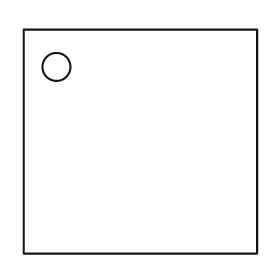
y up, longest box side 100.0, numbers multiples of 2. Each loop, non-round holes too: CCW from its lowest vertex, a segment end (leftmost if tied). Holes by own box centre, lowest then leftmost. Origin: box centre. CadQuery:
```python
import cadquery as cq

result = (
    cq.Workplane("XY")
    .moveTo(-50.0, -48.0)
    .lineTo(50.0, -48.0)
    .lineTo(50.0, 48.0)
    .lineTo(-50.0, 48.0)
    .close()
    .moveTo(-36.0, 32.0)
    .circle(6.0)
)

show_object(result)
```